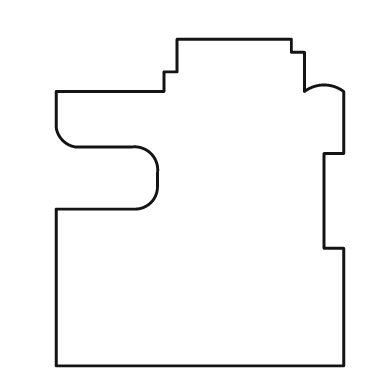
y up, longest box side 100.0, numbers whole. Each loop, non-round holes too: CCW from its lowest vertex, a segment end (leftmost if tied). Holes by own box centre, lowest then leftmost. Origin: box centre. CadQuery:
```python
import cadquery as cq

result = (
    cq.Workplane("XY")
    .moveTo(-44.0, -50.0)
    .lineTo(44.0, -50.0)
    .lineTo(44.0, -14.0)
    .lineTo(38.0, -14.0)
    .lineTo(38.0, 15.0)
    .lineTo(44.0, 15.0)
    .lineTo(44.0, 34.0)
    .threePointArc((38.0, 36.0), (32.0, 34.0))
    .lineTo(32.0, 46.0)
    .lineTo(28.0, 46.0)
    .lineTo(28.0, 50.0)
    .lineTo(-7.0, 50.0)
    .lineTo(-7.0, 40.0)
    .lineTo(-11.0, 40.0)
    .lineTo(-11.0, 34.0)
    .lineTo(-44.0, 34.0)
    .lineTo(-44.0, 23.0)
    .threePointArc((-42.0, 19.0), (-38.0, 17.0))
    .lineTo(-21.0, 17.0)
    .threePointArc((-15.0, 15.0), (-13.0, 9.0))
    .lineTo(-13.0, 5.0)
    .threePointArc((-15.0, 0.0), (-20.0, -2.0))
    .lineTo(-44.0, -2.0)
    .close()
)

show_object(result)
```